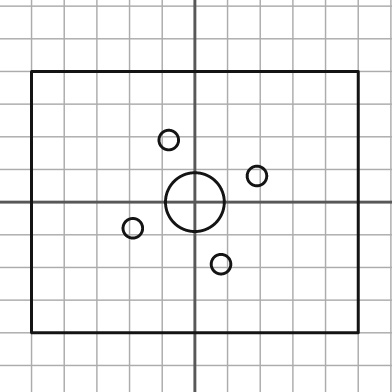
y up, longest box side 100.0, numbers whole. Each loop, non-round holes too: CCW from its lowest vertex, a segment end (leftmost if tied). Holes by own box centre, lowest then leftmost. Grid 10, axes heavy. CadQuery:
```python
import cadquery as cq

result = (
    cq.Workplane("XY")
    .moveTo(-50.0, -40.0)
    .lineTo(50.0, -40.0)
    .lineTo(50.0, 40.0)
    .lineTo(-50.0, 40.0)
    .close()
    .moveTo(8.0, -19.0)
    .circle(3.0)
    .moveTo(-19.0, -8.0)
    .circle(3.0)
    .moveTo(0.0, 0.0)
    .circle(9.0)
    .moveTo(19.0, 8.0)
    .circle(3.0)
    .moveTo(-8.0, 19.0)
    .circle(3.0)
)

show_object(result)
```